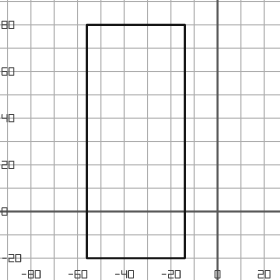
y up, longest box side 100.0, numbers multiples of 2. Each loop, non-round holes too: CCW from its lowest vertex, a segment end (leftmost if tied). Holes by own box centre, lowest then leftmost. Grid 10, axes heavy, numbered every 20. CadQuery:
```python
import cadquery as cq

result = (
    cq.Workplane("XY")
    .moveTo(-56.0, -20.0)
    .lineTo(-14.0, -20.0)
    .lineTo(-14.0, 80.0)
    .lineTo(-56.0, 80.0)
    .close()
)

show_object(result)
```